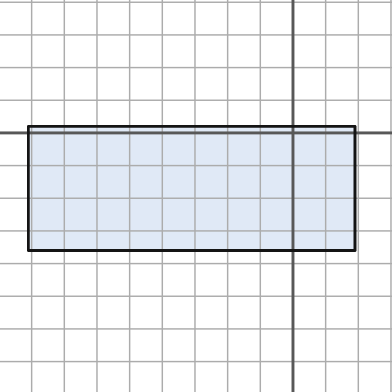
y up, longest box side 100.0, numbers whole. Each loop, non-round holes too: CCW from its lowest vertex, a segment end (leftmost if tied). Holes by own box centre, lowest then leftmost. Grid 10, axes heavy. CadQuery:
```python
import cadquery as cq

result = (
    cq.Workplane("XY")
    .moveTo(-81.0, -36.0)
    .lineTo(19.0, -36.0)
    .lineTo(19.0, 2.0)
    .lineTo(-81.0, 2.0)
    .close()
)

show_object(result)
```